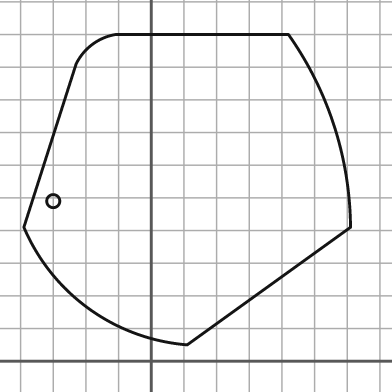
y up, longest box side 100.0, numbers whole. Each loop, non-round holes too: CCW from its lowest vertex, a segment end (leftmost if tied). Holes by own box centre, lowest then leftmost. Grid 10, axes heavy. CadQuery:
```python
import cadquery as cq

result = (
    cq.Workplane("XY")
    .moveTo(11.0, 5.0)
    .lineTo(61.0, 41.0)
    .threePointArc((56.0, 72.0), (42.0, 100.0))
    .lineTo(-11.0, 100.0)
    .threePointArc((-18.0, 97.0), (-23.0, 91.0))
    .lineTo(-39.0, 41.0)
    .threePointArc((-19.0, 16.0), (11.0, 5.0))
    .close()
    .moveTo(-30.0, 49.0)
    .circle(2.0)
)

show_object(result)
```